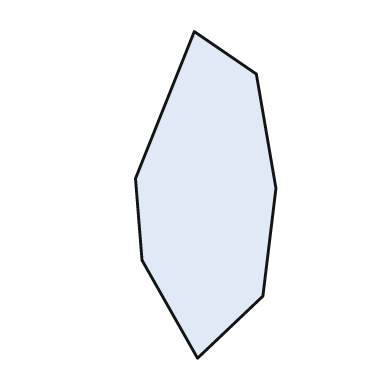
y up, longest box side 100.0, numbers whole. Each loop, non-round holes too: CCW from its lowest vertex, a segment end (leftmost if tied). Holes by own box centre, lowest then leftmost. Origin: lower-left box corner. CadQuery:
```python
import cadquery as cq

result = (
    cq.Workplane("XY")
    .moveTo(19.0, 0.0)
    .lineTo(39.0, 19.0)
    .lineTo(43.0, 52.0)
    .lineTo(37.0, 87.0)
    .lineTo(18.0, 100.0)
    .lineTo(0.0, 55.0)
    .lineTo(2.0, 30.0)
    .close()
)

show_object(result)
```